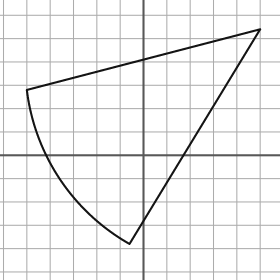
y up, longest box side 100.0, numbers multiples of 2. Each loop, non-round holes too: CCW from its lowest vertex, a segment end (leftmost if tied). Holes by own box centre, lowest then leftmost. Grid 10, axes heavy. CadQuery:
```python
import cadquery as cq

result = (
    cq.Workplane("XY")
    .moveTo(-6.0, -38.0)
    .lineTo(50.0, 54.0)
    .lineTo(-50.0, 28.0)
    .threePointArc((-36.0, -10.0), (-6.0, -38.0))
    .close()
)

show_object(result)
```